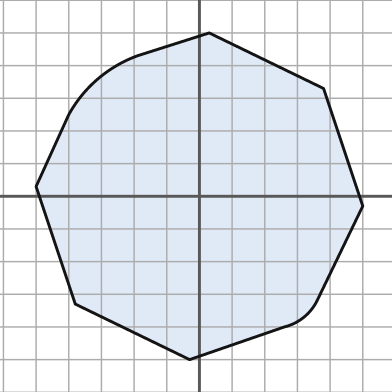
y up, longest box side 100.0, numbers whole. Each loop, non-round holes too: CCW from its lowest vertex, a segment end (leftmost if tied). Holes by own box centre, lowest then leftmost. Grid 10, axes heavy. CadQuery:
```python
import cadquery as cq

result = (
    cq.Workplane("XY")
    .moveTo(-3.0, -50.0)
    .lineTo(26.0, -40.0)
    .threePointArc((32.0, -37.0), (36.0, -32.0))
    .lineTo(50.0, -3.0)
    .lineTo(38.0, 33.0)
    .lineTo(3.0, 50.0)
    .lineTo(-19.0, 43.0)
    .threePointArc((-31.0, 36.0), (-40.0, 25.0))
    .lineTo(-50.0, 3.0)
    .lineTo(-38.0, -33.0)
    .close()
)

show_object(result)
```